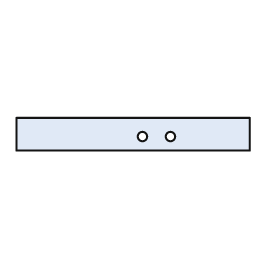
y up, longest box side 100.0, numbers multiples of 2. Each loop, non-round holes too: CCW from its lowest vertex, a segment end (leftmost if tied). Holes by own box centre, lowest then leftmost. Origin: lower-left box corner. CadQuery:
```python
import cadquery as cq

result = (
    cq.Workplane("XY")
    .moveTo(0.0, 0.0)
    .lineTo(100.0, 0.0)
    .lineTo(100.0, 14.0)
    .lineTo(0.0, 14.0)
    .close()
    .moveTo(54.0, 6.0)
    .circle(2.0)
    .moveTo(66.0, 6.0)
    .circle(2.0)
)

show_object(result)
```